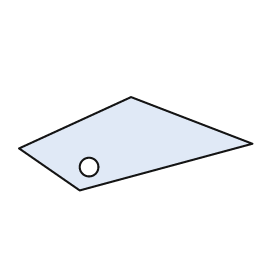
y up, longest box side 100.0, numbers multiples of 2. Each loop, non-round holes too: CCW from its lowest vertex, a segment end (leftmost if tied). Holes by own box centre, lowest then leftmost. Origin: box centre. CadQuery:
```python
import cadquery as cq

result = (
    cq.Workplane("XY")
    .moveTo(-24.0, -20.0)
    .lineTo(50.0, 0.0)
    .lineTo(-2.0, 20.0)
    .lineTo(-50.0, -2.0)
    .close()
    .moveTo(-20.0, -10.0)
    .circle(4.0)
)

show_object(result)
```